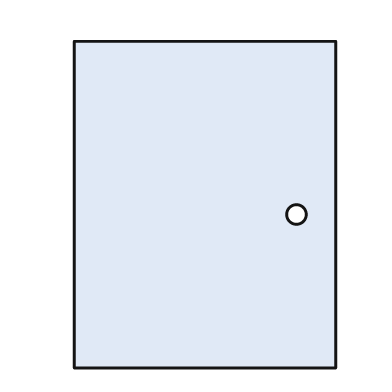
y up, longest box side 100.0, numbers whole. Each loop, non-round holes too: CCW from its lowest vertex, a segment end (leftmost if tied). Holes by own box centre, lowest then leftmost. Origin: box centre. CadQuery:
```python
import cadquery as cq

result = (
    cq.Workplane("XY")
    .moveTo(-40.0, -50.0)
    .lineTo(40.0, -50.0)
    .lineTo(40.0, 50.0)
    .lineTo(-40.0, 50.0)
    .close()
    .moveTo(28.0, -3.0)
    .circle(3.0)
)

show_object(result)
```